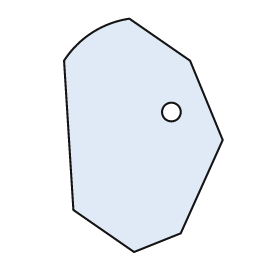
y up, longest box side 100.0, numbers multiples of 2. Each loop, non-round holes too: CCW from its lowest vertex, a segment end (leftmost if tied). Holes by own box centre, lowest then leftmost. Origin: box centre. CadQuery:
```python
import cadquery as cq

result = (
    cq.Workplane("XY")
    .moveTo(-4.0, -50.0)
    .lineTo(16.0, -42.0)
    .lineTo(34.0, -2.0)
    .lineTo(20.0, 32.0)
    .lineTo(-6.0, 50.0)
    .threePointArc((-22.0, 44.0), (-34.0, 32.0))
    .lineTo(-30.0, -32.0)
    .close()
    .moveTo(12.0, 10.0)
    .circle(4.0)
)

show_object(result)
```